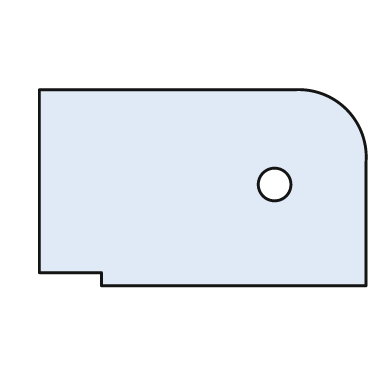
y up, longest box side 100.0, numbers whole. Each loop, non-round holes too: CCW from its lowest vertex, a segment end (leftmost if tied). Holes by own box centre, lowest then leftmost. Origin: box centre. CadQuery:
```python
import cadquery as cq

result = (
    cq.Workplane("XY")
    .moveTo(-31.0, -30.0)
    .lineTo(50.0, -30.0)
    .lineTo(50.0, 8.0)
    .threePointArc((44.0, 24.0), (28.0, 30.0))
    .lineTo(-50.0, 30.0)
    .lineTo(-50.0, -26.0)
    .lineTo(-31.0, -26.0)
    .close()
    .moveTo(22.0, 1.0)
    .circle(5.0)
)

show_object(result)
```